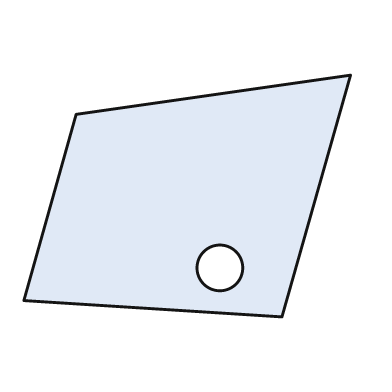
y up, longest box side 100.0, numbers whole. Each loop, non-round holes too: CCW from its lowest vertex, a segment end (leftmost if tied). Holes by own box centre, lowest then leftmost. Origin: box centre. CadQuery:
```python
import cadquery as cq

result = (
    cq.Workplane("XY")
    .moveTo(29.0, -37.0)
    .lineTo(50.0, 37.0)
    .lineTo(-34.0, 25.0)
    .lineTo(-50.0, -32.0)
    .close()
    .moveTo(10.0, -22.0)
    .circle(7.0)
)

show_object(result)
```